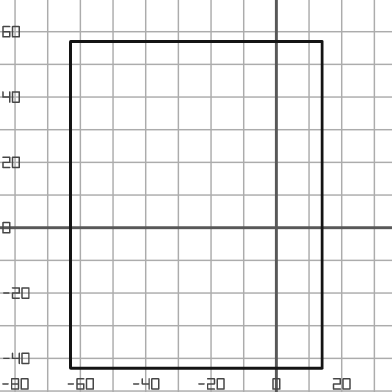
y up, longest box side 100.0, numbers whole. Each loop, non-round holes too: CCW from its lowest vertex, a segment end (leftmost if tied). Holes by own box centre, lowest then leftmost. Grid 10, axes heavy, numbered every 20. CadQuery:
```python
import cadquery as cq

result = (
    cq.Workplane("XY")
    .moveTo(-63.0, -43.0)
    .lineTo(14.0, -43.0)
    .lineTo(14.0, 57.0)
    .lineTo(-63.0, 57.0)
    .close()
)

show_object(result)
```